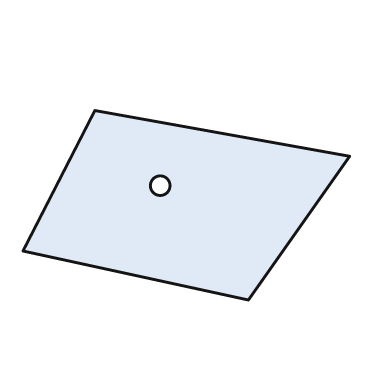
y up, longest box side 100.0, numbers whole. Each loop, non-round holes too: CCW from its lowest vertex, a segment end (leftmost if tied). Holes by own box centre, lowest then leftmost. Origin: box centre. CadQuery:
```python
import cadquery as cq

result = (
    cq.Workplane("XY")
    .moveTo(19.0, -29.0)
    .lineTo(50.0, 15.0)
    .lineTo(-28.0, 29.0)
    .lineTo(-50.0, -14.0)
    .close()
    .moveTo(-8.0, 6.0)
    .circle(3.0)
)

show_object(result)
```